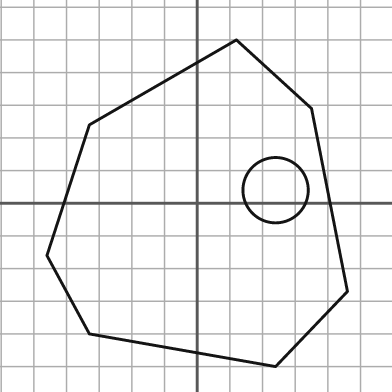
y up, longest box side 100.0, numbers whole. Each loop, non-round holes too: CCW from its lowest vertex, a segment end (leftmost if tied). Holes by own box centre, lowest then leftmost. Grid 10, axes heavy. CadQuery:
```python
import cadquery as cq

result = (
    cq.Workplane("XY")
    .moveTo(24.0, -50.0)
    .lineTo(46.0, -27.0)
    .lineTo(35.0, 29.0)
    .lineTo(12.0, 50.0)
    .lineTo(-33.0, 24.0)
    .lineTo(-46.0, -16.0)
    .lineTo(-33.0, -40.0)
    .close()
    .moveTo(24.0, 4.0)
    .circle(10.0)
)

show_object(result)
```